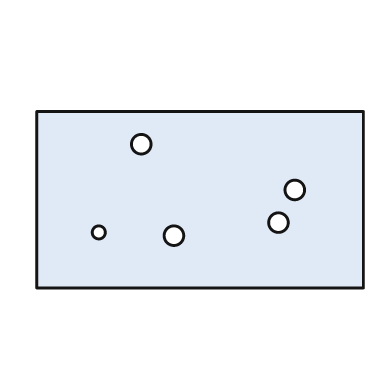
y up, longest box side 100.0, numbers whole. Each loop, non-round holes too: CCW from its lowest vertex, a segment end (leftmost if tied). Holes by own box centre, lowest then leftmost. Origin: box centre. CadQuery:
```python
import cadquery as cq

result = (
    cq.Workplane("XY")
    .moveTo(-50.0, -27.0)
    .lineTo(50.0, -27.0)
    .lineTo(50.0, 27.0)
    .lineTo(-50.0, 27.0)
    .close()
    .moveTo(-8.0, -11.0)
    .circle(3.0)
    .moveTo(-31.0, -10.0)
    .circle(2.0)
    .moveTo(24.0, -7.0)
    .circle(3.0)
    .moveTo(29.0, 3.0)
    .circle(3.0)
    .moveTo(-18.0, 17.0)
    .circle(3.0)
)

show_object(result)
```